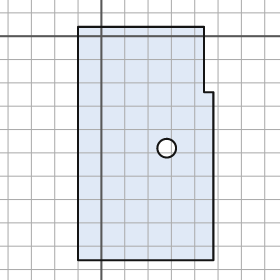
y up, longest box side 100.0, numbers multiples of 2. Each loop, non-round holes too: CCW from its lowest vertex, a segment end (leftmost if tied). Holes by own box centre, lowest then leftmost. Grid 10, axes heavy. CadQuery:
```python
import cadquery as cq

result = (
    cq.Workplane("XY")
    .moveTo(-10.0, -96.0)
    .lineTo(48.0, -96.0)
    .lineTo(48.0, -24.0)
    .lineTo(44.0, -24.0)
    .lineTo(44.0, 4.0)
    .lineTo(-10.0, 4.0)
    .close()
    .moveTo(28.0, -48.0)
    .circle(4.0)
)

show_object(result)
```